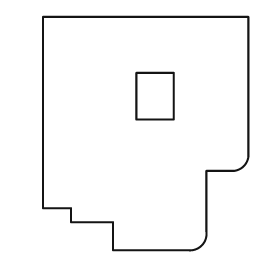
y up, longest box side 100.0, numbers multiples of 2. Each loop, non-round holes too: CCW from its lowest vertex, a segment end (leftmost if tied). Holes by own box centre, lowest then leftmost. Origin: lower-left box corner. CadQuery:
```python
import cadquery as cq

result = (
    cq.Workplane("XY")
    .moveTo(30.0, 0.0)
    .lineTo(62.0, 0.0)
    .threePointArc((68.0, 2.0), (70.0, 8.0))
    .lineTo(70.0, 34.0)
    .lineTo(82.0, 34.0)
    .threePointArc((86.0, 36.0), (88.0, 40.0))
    .lineTo(88.0, 100.0)
    .lineTo(0.0, 100.0)
    .lineTo(0.0, 18.0)
    .lineTo(12.0, 18.0)
    .lineTo(12.0, 12.0)
    .lineTo(30.0, 12.0)
    .close()
    .moveTo(40.0, 56.0)
    .lineTo(56.0, 56.0)
    .lineTo(56.0, 76.0)
    .lineTo(40.0, 76.0)
    .close()
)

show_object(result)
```